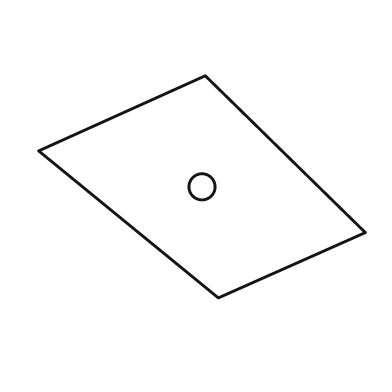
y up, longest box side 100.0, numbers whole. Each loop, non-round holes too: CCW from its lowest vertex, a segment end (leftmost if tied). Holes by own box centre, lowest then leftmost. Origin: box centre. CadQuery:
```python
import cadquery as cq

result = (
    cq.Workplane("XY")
    .moveTo(5.0, -34.0)
    .lineTo(50.0, -14.0)
    .lineTo(1.0, 34.0)
    .lineTo(-50.0, 11.0)
    .close()
    .moveTo(0.0, 0.0)
    .circle(4.0)
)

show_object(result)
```